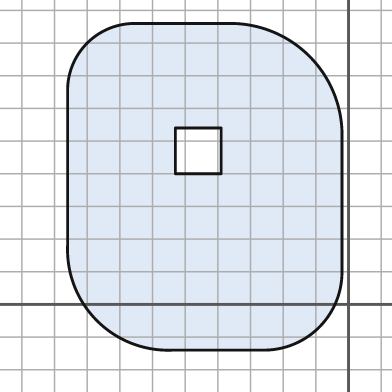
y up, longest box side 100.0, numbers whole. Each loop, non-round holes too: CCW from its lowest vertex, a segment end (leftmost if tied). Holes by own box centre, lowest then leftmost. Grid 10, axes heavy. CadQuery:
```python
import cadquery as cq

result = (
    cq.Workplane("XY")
    .moveTo(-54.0, -14.0)
    .lineTo(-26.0, -14.0)
    .threePointArc((-9.0, -7.0), (-2.0, 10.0))
    .lineTo(-2.0, 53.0)
    .threePointArc((-12.0, 76.0), (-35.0, 86.0))
    .lineTo(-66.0, 86.0)
    .threePointArc((-80.0, 80.0), (-86.0, 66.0))
    .lineTo(-86.0, 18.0)
    .threePointArc((-77.0, -5.0), (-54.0, -14.0))
    .close()
    .moveTo(-53.0, 40.0)
    .lineTo(-39.0, 40.0)
    .lineTo(-39.0, 54.0)
    .lineTo(-53.0, 54.0)
    .close()
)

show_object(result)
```